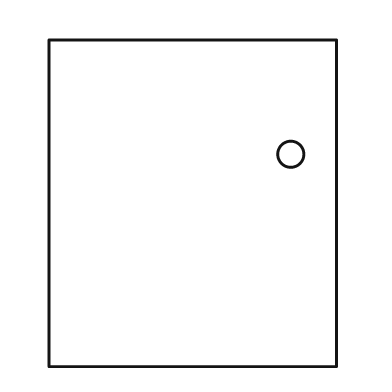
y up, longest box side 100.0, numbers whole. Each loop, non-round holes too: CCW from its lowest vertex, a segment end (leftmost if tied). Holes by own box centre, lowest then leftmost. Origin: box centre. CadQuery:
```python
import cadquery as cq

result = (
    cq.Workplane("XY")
    .moveTo(-44.0, -50.0)
    .lineTo(44.0, -50.0)
    .lineTo(44.0, 50.0)
    .lineTo(-44.0, 50.0)
    .close()
    .moveTo(30.0, 15.0)
    .circle(4.0)
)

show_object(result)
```